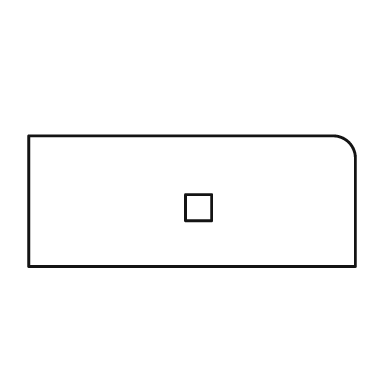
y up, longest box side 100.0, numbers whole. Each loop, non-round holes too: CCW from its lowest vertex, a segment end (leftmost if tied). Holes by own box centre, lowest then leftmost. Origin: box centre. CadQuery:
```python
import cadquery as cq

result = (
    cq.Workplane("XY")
    .moveTo(-50.0, -20.0)
    .lineTo(50.0, -20.0)
    .lineTo(50.0, 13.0)
    .threePointArc((48.0, 18.0), (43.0, 20.0))
    .lineTo(-50.0, 20.0)
    .close()
    .moveTo(-2.0, -6.0)
    .lineTo(6.0, -6.0)
    .lineTo(6.0, 2.0)
    .lineTo(-2.0, 2.0)
    .close()
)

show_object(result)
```